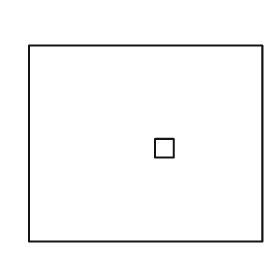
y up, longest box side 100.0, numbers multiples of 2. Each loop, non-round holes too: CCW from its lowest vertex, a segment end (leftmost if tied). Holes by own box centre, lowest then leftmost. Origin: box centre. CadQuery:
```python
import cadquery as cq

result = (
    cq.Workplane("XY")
    .moveTo(-50.0, -42.0)
    .lineTo(50.0, -42.0)
    .lineTo(50.0, 42.0)
    .lineTo(-50.0, 42.0)
    .close()
    .moveTo(4.0, -6.0)
    .lineTo(12.0, -6.0)
    .lineTo(12.0, 2.0)
    .lineTo(4.0, 2.0)
    .close()
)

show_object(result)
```